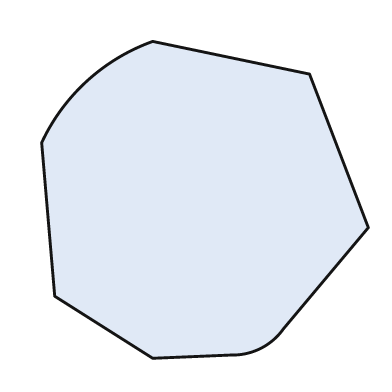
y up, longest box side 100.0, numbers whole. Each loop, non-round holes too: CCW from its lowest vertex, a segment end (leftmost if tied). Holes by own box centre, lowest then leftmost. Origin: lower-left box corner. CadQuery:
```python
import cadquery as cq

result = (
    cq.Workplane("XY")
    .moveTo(34.0, 0.0)
    .lineTo(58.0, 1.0)
    .threePointArc((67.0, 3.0), (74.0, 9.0))
    .lineTo(100.0, 40.0)
    .lineTo(82.0, 87.0)
    .lineTo(34.0, 97.0)
    .threePointArc((14.0, 85.0), (0.0, 66.0))
    .lineTo(4.0, 19.0)
    .close()
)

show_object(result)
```